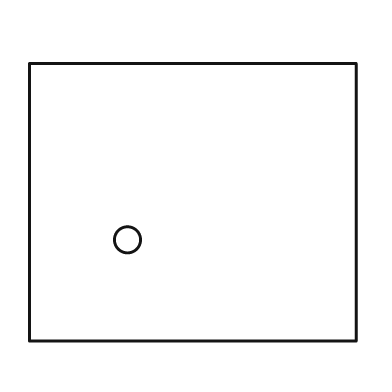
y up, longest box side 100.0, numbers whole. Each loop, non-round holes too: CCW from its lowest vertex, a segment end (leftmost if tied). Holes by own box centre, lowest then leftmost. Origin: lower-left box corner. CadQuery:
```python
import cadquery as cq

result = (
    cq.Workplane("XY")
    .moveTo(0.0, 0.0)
    .lineTo(100.0, 0.0)
    .lineTo(100.0, 85.0)
    .lineTo(0.0, 85.0)
    .close()
    .moveTo(30.0, 31.0)
    .circle(4.0)
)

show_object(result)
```